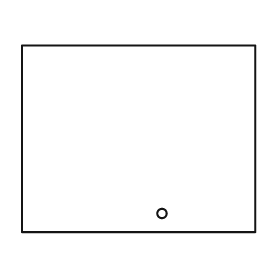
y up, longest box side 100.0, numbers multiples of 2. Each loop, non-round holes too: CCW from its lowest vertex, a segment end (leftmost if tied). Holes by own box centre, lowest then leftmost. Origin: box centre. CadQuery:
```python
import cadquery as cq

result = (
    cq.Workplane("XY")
    .moveTo(-50.0, -40.0)
    .lineTo(50.0, -40.0)
    .lineTo(50.0, 40.0)
    .lineTo(-50.0, 40.0)
    .close()
    .moveTo(10.0, -32.0)
    .circle(2.0)
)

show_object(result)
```